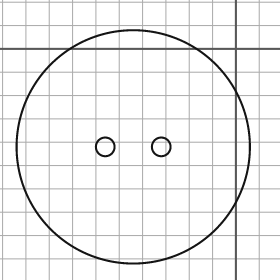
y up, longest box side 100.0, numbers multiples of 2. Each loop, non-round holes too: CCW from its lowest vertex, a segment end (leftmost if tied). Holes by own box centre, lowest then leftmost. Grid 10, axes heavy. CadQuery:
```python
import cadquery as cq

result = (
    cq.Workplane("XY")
    .moveTo(-44.0, -42.0)
    .circle(50.0)
    .moveTo(-56.0, -42.0)
    .circle(4.0)
    .moveTo(-32.0, -42.0)
    .circle(4.0)
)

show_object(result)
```